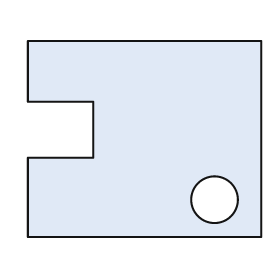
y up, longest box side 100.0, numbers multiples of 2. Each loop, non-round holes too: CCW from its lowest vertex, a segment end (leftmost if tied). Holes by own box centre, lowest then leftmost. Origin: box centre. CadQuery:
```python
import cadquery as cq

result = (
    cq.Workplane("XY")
    .moveTo(-50.0, -42.0)
    .lineTo(50.0, -42.0)
    .lineTo(50.0, 42.0)
    .lineTo(-50.0, 42.0)
    .lineTo(-50.0, 16.0)
    .lineTo(-22.0, 16.0)
    .lineTo(-22.0, -8.0)
    .lineTo(-50.0, -8.0)
    .close()
    .moveTo(30.0, -26.0)
    .circle(10.0)
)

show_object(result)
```